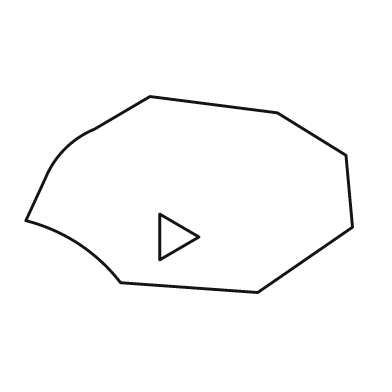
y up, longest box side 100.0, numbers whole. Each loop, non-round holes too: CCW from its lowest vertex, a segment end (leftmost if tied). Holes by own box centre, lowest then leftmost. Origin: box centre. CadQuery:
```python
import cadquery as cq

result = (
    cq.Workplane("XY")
    .moveTo(21.0, -30.0)
    .lineTo(50.0, -10.0)
    .lineTo(48.0, 12.0)
    .lineTo(27.0, 25.0)
    .lineTo(-12.0, 30.0)
    .lineTo(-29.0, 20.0)
    .threePointArc((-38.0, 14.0), (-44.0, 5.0))
    .lineTo(-50.0, -8.0)
    .threePointArc((-34.0, -15.0), (-21.0, -27.0))
    .close()
    .moveTo(-9.0, -20.0)
    .lineTo(3.0, -13.0)
    .lineTo(-9.0, -6.0)
    .close()
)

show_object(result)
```